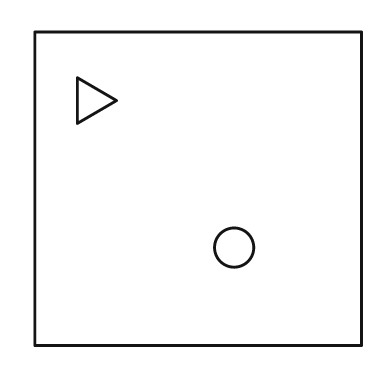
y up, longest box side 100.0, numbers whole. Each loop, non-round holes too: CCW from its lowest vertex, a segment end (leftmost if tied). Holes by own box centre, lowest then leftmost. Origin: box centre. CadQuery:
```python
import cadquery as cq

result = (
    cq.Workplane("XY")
    .moveTo(-50.0, -48.0)
    .lineTo(50.0, -48.0)
    .lineTo(50.0, 48.0)
    .lineTo(-50.0, 48.0)
    .close()
    .moveTo(11.0, -18.0)
    .circle(6.0)
    .moveTo(-37.0, 20.0)
    .lineTo(-25.0, 27.0)
    .lineTo(-37.0, 34.0)
    .close()
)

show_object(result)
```